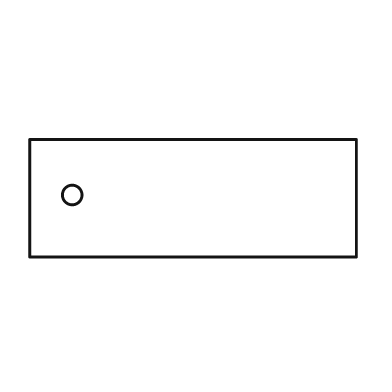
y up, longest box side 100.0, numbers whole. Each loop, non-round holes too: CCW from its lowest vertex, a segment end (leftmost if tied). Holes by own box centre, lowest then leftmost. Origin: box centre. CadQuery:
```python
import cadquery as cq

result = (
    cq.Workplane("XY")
    .moveTo(-50.0, -18.0)
    .lineTo(50.0, -18.0)
    .lineTo(50.0, 18.0)
    .lineTo(-50.0, 18.0)
    .close()
    .moveTo(-37.0, 1.0)
    .circle(3.0)
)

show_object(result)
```